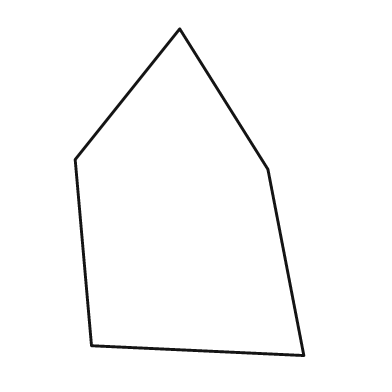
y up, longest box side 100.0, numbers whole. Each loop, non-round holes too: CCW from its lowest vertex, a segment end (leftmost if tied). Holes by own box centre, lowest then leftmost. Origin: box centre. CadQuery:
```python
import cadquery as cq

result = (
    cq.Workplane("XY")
    .moveTo(35.0, -50.0)
    .lineTo(24.0, 7.0)
    .lineTo(-3.0, 50.0)
    .lineTo(-35.0, 10.0)
    .lineTo(-30.0, -47.0)
    .close()
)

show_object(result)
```